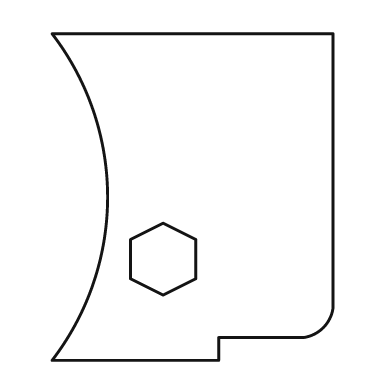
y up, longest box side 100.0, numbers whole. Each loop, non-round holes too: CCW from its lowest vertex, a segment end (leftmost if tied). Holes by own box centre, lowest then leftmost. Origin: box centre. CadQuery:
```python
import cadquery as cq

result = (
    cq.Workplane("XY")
    .moveTo(-43.0, -50.0)
    .lineTo(8.0, -50.0)
    .lineTo(8.0, -43.0)
    .lineTo(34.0, -43.0)
    .threePointArc((40.0, -40.0), (43.0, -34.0))
    .lineTo(43.0, 50.0)
    .lineTo(-43.0, 50.0)
    .threePointArc((-26.0, 0.0), (-43.0, -50.0))
    .close()
    .moveTo(-9.0, -30.0)
    .lineTo(1.0, -25.0)
    .lineTo(1.0, -13.0)
    .lineTo(-9.0, -8.0)
    .lineTo(-19.0, -13.0)
    .lineTo(-19.0, -25.0)
    .close()
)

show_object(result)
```